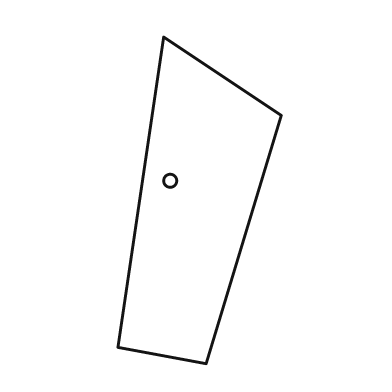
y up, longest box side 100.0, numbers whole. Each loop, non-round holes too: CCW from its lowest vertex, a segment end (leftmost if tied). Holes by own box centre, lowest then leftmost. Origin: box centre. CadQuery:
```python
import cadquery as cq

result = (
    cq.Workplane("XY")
    .moveTo(2.0, -50.0)
    .lineTo(25.0, 26.0)
    .lineTo(-11.0, 50.0)
    .lineTo(-25.0, -45.0)
    .close()
    .moveTo(-9.0, 6.0)
    .circle(2.0)
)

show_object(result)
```